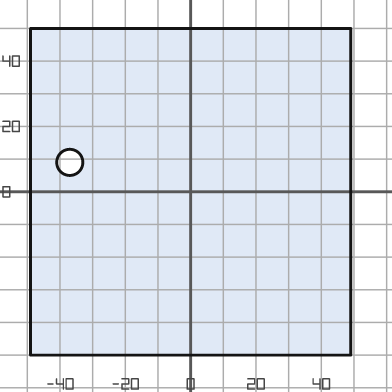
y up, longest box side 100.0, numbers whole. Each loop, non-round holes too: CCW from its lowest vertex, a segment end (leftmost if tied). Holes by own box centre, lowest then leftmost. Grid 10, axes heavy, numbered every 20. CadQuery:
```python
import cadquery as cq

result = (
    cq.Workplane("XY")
    .moveTo(-49.0, -50.0)
    .lineTo(49.0, -50.0)
    .lineTo(49.0, 50.0)
    .lineTo(-49.0, 50.0)
    .close()
    .moveTo(-37.0, 9.0)
    .circle(4.0)
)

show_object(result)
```